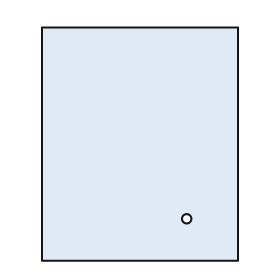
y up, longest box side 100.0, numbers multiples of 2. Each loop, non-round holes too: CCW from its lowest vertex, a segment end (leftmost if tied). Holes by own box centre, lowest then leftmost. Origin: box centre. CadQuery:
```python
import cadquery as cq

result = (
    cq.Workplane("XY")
    .moveTo(-42.0, -50.0)
    .lineTo(42.0, -50.0)
    .lineTo(42.0, 50.0)
    .lineTo(-42.0, 50.0)
    .close()
    .moveTo(20.0, -32.0)
    .circle(2.0)
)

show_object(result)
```